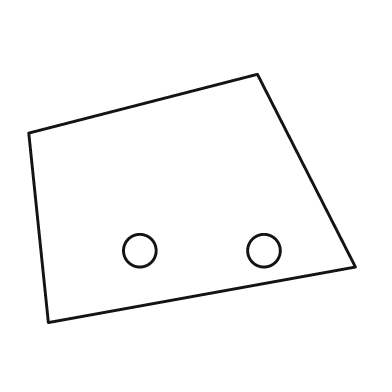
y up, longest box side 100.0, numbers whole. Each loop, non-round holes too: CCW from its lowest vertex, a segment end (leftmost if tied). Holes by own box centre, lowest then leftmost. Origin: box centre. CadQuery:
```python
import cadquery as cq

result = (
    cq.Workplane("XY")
    .moveTo(-44.0, -38.0)
    .lineTo(50.0, -21.0)
    .lineTo(20.0, 38.0)
    .lineTo(-50.0, 20.0)
    .close()
    .moveTo(-16.0, -16.0)
    .circle(5.0)
    .moveTo(22.0, -16.0)
    .circle(5.0)
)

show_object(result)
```